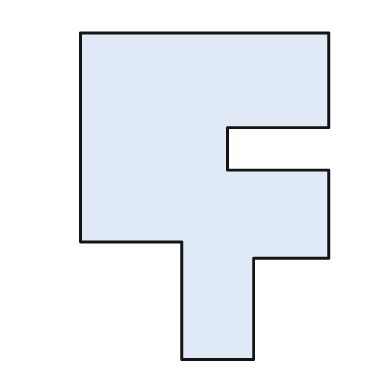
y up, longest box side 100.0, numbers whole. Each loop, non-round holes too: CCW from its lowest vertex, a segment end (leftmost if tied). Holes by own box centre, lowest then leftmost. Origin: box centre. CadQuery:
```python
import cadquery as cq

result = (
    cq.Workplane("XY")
    .moveTo(-7.0, -50.0)
    .lineTo(15.0, -50.0)
    .lineTo(15.0, -19.0)
    .lineTo(38.0, -19.0)
    .lineTo(38.0, 8.0)
    .lineTo(7.0, 8.0)
    .lineTo(7.0, 21.0)
    .lineTo(38.0, 21.0)
    .lineTo(38.0, 50.0)
    .lineTo(-38.0, 50.0)
    .lineTo(-38.0, -14.0)
    .lineTo(-7.0, -14.0)
    .close()
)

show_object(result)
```